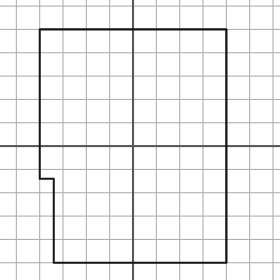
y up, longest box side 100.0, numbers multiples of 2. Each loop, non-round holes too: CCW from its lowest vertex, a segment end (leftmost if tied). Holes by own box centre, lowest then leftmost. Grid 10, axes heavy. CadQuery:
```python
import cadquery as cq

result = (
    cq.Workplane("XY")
    .moveTo(-34.0, -50.0)
    .lineTo(40.0, -50.0)
    .lineTo(40.0, 50.0)
    .lineTo(-40.0, 50.0)
    .lineTo(-40.0, -14.0)
    .lineTo(-34.0, -14.0)
    .close()
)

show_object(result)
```